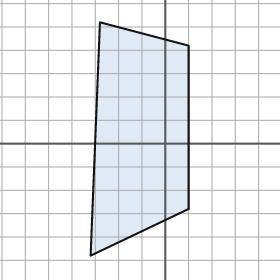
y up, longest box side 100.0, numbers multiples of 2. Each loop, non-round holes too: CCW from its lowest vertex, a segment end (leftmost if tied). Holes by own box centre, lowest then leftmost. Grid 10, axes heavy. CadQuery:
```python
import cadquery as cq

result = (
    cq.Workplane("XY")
    .moveTo(-32.0, -48.0)
    .lineTo(10.0, -28.0)
    .lineTo(10.0, 42.0)
    .lineTo(-28.0, 52.0)
    .close()
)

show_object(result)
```